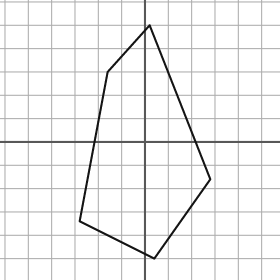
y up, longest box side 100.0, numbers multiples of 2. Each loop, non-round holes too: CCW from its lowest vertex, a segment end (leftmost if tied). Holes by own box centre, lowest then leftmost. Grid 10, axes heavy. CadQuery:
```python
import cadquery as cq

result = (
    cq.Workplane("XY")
    .moveTo(4.0, -50.0)
    .lineTo(28.0, -16.0)
    .lineTo(2.0, 50.0)
    .lineTo(-16.0, 30.0)
    .lineTo(-28.0, -34.0)
    .close()
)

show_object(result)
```